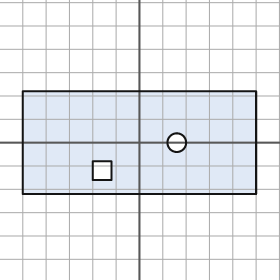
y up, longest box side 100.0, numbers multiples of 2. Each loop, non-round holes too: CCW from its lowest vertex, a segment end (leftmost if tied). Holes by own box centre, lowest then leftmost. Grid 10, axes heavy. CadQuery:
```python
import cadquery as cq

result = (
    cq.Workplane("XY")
    .moveTo(-50.0, -22.0)
    .lineTo(50.0, -22.0)
    .lineTo(50.0, 22.0)
    .lineTo(-50.0, 22.0)
    .close()
    .moveTo(-20.0, -16.0)
    .lineTo(-12.0, -16.0)
    .lineTo(-12.0, -8.0)
    .lineTo(-20.0, -8.0)
    .close()
    .moveTo(16.0, 0.0)
    .circle(4.0)
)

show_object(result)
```